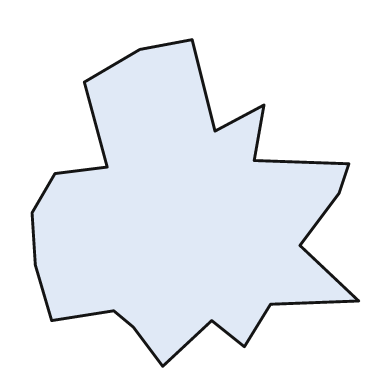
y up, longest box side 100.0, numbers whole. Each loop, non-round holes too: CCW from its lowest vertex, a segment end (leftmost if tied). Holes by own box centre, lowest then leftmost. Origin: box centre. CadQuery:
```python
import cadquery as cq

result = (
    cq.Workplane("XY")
    .moveTo(-10.0, -50.0)
    .lineTo(5.0, -36.0)
    .lineTo(15.0, -44.0)
    .lineTo(23.0, -31.0)
    .lineTo(50.0, -30.0)
    .lineTo(32.0, -13.0)
    .lineTo(44.0, 3.0)
    .lineTo(47.0, 12.0)
    .lineTo(18.0, 13.0)
    .lineTo(21.0, 30.0)
    .lineTo(6.0, 22.0)
    .lineTo(-1.0, 50.0)
    .lineTo(-17.0, 47.0)
    .lineTo(-34.0, 37.0)
    .lineTo(-27.0, 11.0)
    .lineTo(-43.0, 9.0)
    .lineTo(-50.0, -3.0)
    .lineTo(-49.0, -19.0)
    .lineTo(-44.0, -36.0)
    .lineTo(-25.0, -33.0)
    .lineTo(-19.0, -38.0)
    .close()
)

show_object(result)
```